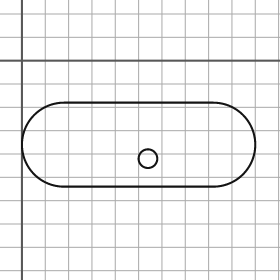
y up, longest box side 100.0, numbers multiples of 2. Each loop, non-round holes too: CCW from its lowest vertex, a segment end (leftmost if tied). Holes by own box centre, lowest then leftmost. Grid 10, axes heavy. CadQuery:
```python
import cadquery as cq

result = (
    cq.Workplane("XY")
    .moveTo(18.0, -54.0)
    .lineTo(82.0, -54.0)
    .threePointArc((100.0, -36.0), (82.0, -18.0))
    .lineTo(18.0, -18.0)
    .threePointArc((0.0, -36.0), (18.0, -54.0))
    .close()
    .moveTo(54.0, -42.0)
    .circle(4.0)
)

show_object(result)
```